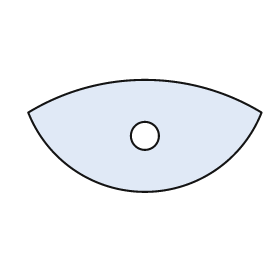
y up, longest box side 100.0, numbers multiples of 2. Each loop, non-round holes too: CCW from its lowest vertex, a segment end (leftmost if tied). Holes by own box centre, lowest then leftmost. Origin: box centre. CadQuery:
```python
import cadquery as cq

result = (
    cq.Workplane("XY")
    .moveTo(-50.0, 10.0)
    .threePointArc((0.0, -24.0), (50.0, 10.0))
    .threePointArc((0.0, 24.0), (-50.0, 10.0))
    .close()
    .moveTo(0.0, 0.0)
    .circle(6.0)
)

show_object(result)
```